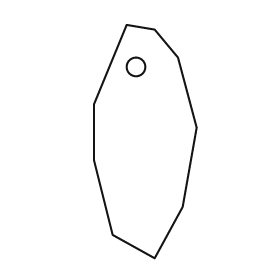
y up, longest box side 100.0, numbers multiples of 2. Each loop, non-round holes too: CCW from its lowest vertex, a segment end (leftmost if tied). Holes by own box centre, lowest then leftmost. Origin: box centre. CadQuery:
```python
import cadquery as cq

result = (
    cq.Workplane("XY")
    .moveTo(4.0, -50.0)
    .lineTo(16.0, -28.0)
    .lineTo(22.0, 6.0)
    .lineTo(14.0, 36.0)
    .lineTo(4.0, 48.0)
    .lineTo(-8.0, 50.0)
    .lineTo(-22.0, 16.0)
    .lineTo(-22.0, -8.0)
    .lineTo(-14.0, -40.0)
    .close()
    .moveTo(-4.0, 32.0)
    .circle(4.0)
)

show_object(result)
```